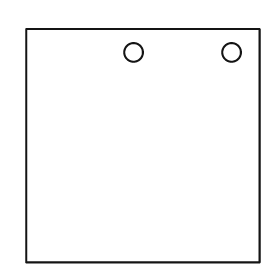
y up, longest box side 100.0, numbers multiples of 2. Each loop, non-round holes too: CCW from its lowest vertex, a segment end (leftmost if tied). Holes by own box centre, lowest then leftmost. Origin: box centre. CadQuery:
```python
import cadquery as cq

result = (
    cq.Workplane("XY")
    .moveTo(-50.0, -50.0)
    .lineTo(50.0, -50.0)
    .lineTo(50.0, 50.0)
    .lineTo(-50.0, 50.0)
    .close()
    .moveTo(-4.0, 40.0)
    .circle(4.0)
    .moveTo(38.0, 40.0)
    .circle(4.0)
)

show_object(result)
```